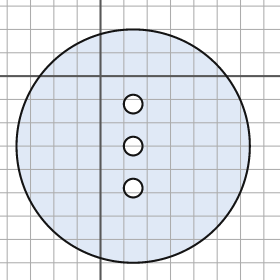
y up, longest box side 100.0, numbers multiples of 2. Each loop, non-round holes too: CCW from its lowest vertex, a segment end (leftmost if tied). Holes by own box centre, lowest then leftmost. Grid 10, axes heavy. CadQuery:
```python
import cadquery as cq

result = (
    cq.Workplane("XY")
    .moveTo(14.0, -30.0)
    .circle(50.0)
    .moveTo(14.0, -48.0)
    .circle(4.0)
    .moveTo(14.0, -30.0)
    .circle(4.0)
    .moveTo(14.0, -12.0)
    .circle(4.0)
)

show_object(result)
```